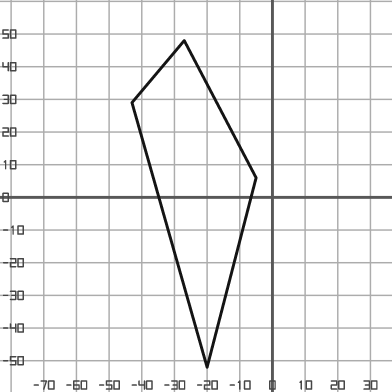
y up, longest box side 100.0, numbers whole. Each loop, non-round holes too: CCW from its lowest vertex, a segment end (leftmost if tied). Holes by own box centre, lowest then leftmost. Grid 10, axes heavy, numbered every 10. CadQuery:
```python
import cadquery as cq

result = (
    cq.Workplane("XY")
    .moveTo(-20.0, -52.0)
    .lineTo(-5.0, 6.0)
    .lineTo(-27.0, 48.0)
    .lineTo(-43.0, 29.0)
    .close()
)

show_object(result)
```